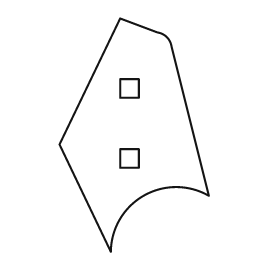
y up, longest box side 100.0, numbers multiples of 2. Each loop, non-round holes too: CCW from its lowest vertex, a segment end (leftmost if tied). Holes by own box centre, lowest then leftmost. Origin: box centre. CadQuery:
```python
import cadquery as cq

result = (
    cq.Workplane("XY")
    .moveTo(-10.0, -50.0)
    .threePointArc((4.0, -26.0), (32.0, -26.0))
    .lineTo(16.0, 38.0)
    .threePointArc((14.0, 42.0), (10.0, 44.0))
    .lineTo(-6.0, 50.0)
    .lineTo(-32.0, -4.0)
    .close()
    .moveTo(-6.0, -14.0)
    .lineTo(2.0, -14.0)
    .lineTo(2.0, -6.0)
    .lineTo(-6.0, -6.0)
    .close()
    .moveTo(-6.0, 16.0)
    .lineTo(2.0, 16.0)
    .lineTo(2.0, 24.0)
    .lineTo(-6.0, 24.0)
    .close()
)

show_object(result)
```